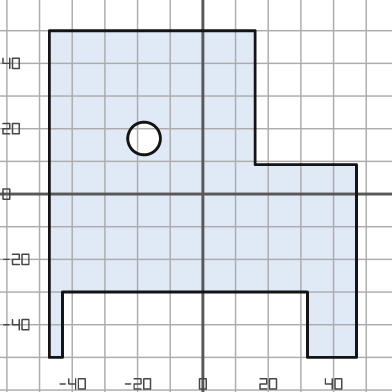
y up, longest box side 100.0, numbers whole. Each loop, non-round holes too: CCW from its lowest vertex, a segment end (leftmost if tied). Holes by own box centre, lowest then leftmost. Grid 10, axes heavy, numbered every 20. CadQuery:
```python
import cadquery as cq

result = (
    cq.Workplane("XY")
    .moveTo(-47.0, -50.0)
    .lineTo(-43.0, -50.0)
    .lineTo(-43.0, -30.0)
    .lineTo(32.0, -30.0)
    .lineTo(32.0, -50.0)
    .lineTo(47.0, -50.0)
    .lineTo(47.0, 9.0)
    .lineTo(16.0, 9.0)
    .lineTo(16.0, 50.0)
    .lineTo(-47.0, 50.0)
    .close()
    .moveTo(-18.0, 17.0)
    .circle(5.0)
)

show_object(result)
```